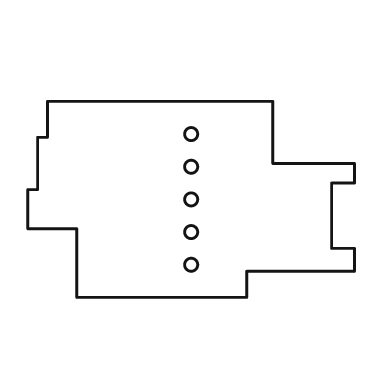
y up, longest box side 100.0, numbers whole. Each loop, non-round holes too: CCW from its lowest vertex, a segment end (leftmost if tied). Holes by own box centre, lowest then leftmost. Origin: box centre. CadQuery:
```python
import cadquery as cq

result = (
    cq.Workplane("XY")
    .moveTo(-35.0, -30.0)
    .lineTo(17.0, -30.0)
    .lineTo(17.0, -22.0)
    .lineTo(50.0, -22.0)
    .lineTo(50.0, -15.0)
    .lineTo(43.0, -15.0)
    .lineTo(43.0, 5.0)
    .lineTo(50.0, 5.0)
    .lineTo(50.0, 11.0)
    .lineTo(25.0, 11.0)
    .lineTo(25.0, 30.0)
    .lineTo(-44.0, 30.0)
    .lineTo(-44.0, 19.0)
    .lineTo(-47.0, 19.0)
    .lineTo(-47.0, 3.0)
    .lineTo(-50.0, 3.0)
    .lineTo(-50.0, -9.0)
    .lineTo(-35.0, -9.0)
    .close()
    .moveTo(0.0, -20.0)
    .circle(2.0)
    .moveTo(0.0, -10.0)
    .circle(2.0)
    .moveTo(0.0, 0.0)
    .circle(2.0)
    .moveTo(0.0, 10.0)
    .circle(2.0)
    .moveTo(0.0, 20.0)
    .circle(2.0)
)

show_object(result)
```